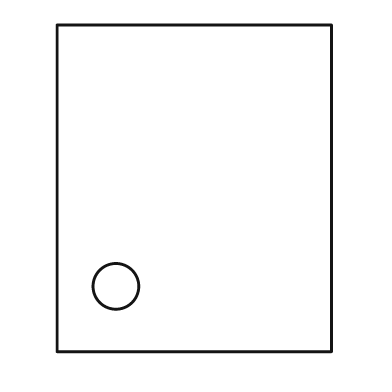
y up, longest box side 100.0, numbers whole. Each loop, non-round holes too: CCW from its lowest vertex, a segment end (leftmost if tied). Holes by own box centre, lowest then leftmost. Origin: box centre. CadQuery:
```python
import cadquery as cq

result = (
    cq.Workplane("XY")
    .moveTo(-42.0, -50.0)
    .lineTo(42.0, -50.0)
    .lineTo(42.0, 50.0)
    .lineTo(-42.0, 50.0)
    .close()
    .moveTo(-24.0, -30.0)
    .circle(7.0)
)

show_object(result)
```